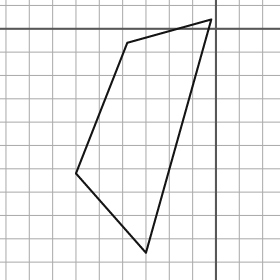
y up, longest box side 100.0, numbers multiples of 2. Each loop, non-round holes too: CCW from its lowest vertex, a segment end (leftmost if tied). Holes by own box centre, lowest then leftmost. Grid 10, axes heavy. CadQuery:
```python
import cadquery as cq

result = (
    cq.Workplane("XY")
    .moveTo(-30.0, -96.0)
    .lineTo(-2.0, 4.0)
    .lineTo(-38.0, -6.0)
    .lineTo(-60.0, -62.0)
    .close()
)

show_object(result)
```